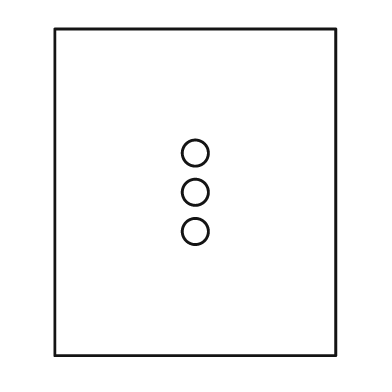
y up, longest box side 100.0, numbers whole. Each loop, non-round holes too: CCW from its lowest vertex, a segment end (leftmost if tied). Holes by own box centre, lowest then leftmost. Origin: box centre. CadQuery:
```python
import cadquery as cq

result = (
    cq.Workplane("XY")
    .moveTo(-43.0, -50.0)
    .lineTo(43.0, -50.0)
    .lineTo(43.0, 50.0)
    .lineTo(-43.0, 50.0)
    .close()
    .moveTo(0.0, -12.0)
    .circle(4.0)
    .moveTo(0.0, 0.0)
    .circle(4.0)
    .moveTo(0.0, 12.0)
    .circle(4.0)
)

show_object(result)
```